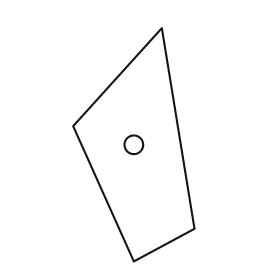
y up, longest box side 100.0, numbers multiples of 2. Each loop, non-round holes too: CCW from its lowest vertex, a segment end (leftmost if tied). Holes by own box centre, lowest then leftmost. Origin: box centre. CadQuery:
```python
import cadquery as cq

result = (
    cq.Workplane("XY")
    .moveTo(0.0, -50.0)
    .lineTo(26.0, -36.0)
    .lineTo(12.0, 50.0)
    .lineTo(-26.0, 8.0)
    .close()
    .moveTo(0.0, 0.0)
    .circle(4.0)
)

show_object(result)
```